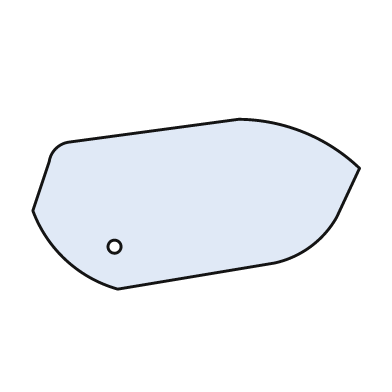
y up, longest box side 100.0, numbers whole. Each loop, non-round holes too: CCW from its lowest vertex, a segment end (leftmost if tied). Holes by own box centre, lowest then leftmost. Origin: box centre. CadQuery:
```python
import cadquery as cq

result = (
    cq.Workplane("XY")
    .moveTo(-24.0, -26.0)
    .lineTo(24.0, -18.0)
    .threePointArc((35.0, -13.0), (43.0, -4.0))
    .lineTo(50.0, 11.0)
    .threePointArc((33.0, 22.0), (13.0, 26.0))
    .lineTo(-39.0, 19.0)
    .threePointArc((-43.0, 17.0), (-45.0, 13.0))
    .lineTo(-50.0, -2.0)
    .threePointArc((-40.0, -17.0), (-24.0, -26.0))
    .close()
    .moveTo(-25.0, -13.0)
    .circle(2.0)
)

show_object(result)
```